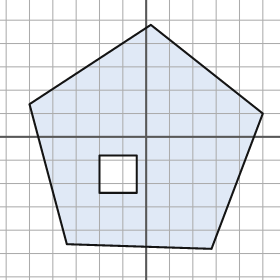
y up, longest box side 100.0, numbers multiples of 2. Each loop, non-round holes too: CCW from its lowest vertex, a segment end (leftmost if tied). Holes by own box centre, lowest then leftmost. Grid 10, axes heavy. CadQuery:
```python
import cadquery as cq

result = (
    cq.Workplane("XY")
    .moveTo(28.0, -48.0)
    .lineTo(50.0, 10.0)
    .lineTo(2.0, 48.0)
    .lineTo(-50.0, 14.0)
    .lineTo(-34.0, -46.0)
    .close()
    .moveTo(-20.0, -24.0)
    .lineTo(-4.0, -24.0)
    .lineTo(-4.0, -8.0)
    .lineTo(-20.0, -8.0)
    .close()
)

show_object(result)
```